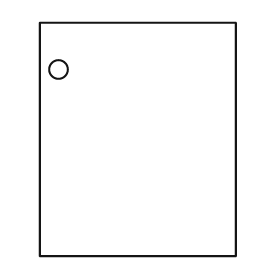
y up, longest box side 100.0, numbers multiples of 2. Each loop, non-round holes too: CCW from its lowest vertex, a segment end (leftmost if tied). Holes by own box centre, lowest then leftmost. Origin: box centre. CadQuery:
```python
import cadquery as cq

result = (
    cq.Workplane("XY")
    .moveTo(-42.0, -50.0)
    .lineTo(42.0, -50.0)
    .lineTo(42.0, 50.0)
    .lineTo(-42.0, 50.0)
    .close()
    .moveTo(-34.0, 30.0)
    .circle(4.0)
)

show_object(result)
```